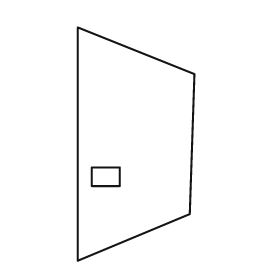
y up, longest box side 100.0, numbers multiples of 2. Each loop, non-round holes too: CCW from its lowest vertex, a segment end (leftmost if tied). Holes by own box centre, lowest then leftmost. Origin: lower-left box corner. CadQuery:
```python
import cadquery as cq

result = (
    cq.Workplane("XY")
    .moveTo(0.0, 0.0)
    .lineTo(48.0, 20.0)
    .lineTo(50.0, 80.0)
    .lineTo(0.0, 100.0)
    .close()
    .moveTo(6.0, 32.0)
    .lineTo(18.0, 32.0)
    .lineTo(18.0, 40.0)
    .lineTo(6.0, 40.0)
    .close()
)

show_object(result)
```